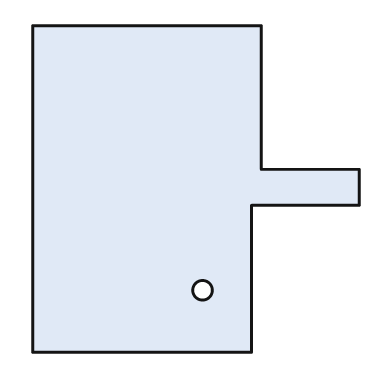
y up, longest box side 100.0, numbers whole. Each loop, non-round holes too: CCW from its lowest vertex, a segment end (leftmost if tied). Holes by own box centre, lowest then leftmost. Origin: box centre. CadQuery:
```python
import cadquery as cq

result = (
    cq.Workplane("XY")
    .moveTo(-50.0, -50.0)
    .lineTo(17.0, -50.0)
    .lineTo(17.0, -5.0)
    .lineTo(50.0, -5.0)
    .lineTo(50.0, 6.0)
    .lineTo(20.0, 6.0)
    .lineTo(20.0, 50.0)
    .lineTo(-50.0, 50.0)
    .close()
    .moveTo(2.0, -31.0)
    .circle(3.0)
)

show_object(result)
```